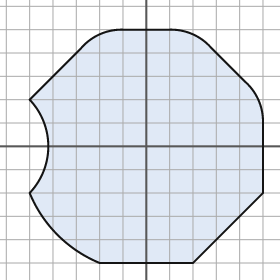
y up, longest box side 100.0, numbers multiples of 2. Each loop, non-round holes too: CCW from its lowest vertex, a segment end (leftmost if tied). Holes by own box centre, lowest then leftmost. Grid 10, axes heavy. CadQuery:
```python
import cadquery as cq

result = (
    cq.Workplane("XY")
    .moveTo(-20.0, -50.0)
    .lineTo(20.0, -50.0)
    .lineTo(50.0, -20.0)
    .lineTo(50.0, 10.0)
    .threePointArc((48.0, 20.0), (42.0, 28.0))
    .lineTo(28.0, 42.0)
    .threePointArc((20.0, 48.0), (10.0, 50.0))
    .lineTo(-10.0, 50.0)
    .threePointArc((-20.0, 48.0), (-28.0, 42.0))
    .lineTo(-50.0, 20.0)
    .threePointArc((-42.0, 0.0), (-50.0, -20.0))
    .threePointArc((-38.0, -38.0), (-20.0, -50.0))
    .close()
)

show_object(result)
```